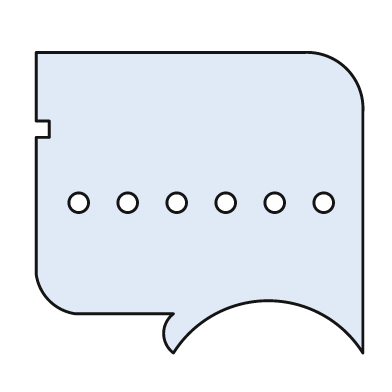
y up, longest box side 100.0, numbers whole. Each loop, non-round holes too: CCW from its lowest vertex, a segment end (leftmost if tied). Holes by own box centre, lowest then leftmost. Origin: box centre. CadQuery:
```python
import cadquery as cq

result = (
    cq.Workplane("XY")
    .moveTo(-8.0, -46.0)
    .threePointArc((21.0, -30.0), (50.0, -46.0))
    .lineTo(50.0, 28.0)
    .threePointArc((45.0, 41.0), (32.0, 46.0))
    .lineTo(-50.0, 46.0)
    .lineTo(-50.0, 25.0)
    .lineTo(-46.0, 25.0)
    .lineTo(-46.0, 20.0)
    .lineTo(-50.0, 20.0)
    .lineTo(-50.0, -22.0)
    .threePointArc((-46.0, -30.0), (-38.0, -34.0))
    .lineTo(-8.0, -34.0)
    .threePointArc((-11.0, -40.0), (-8.0, -46.0))
    .close()
    .moveTo(-37.0, 0.0)
    .circle(3.0)
    .moveTo(-22.0, 0.0)
    .circle(3.0)
    .moveTo(-7.0, 0.0)
    .circle(3.0)
    .moveTo(8.0, 0.0)
    .circle(3.0)
    .moveTo(23.0, 0.0)
    .circle(3.0)
    .moveTo(38.0, 0.0)
    .circle(3.0)
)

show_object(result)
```